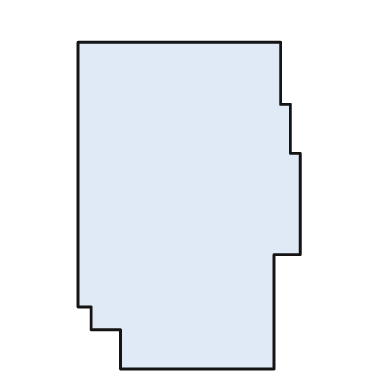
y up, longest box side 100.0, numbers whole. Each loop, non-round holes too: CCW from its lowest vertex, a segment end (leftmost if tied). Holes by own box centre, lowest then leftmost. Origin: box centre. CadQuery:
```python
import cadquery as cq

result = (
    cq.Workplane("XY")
    .moveTo(-21.0, -50.0)
    .lineTo(26.0, -50.0)
    .lineTo(26.0, -15.0)
    .lineTo(34.0, -15.0)
    .lineTo(34.0, 16.0)
    .lineTo(31.0, 16.0)
    .lineTo(31.0, 31.0)
    .lineTo(28.0, 31.0)
    .lineTo(28.0, 50.0)
    .lineTo(-34.0, 50.0)
    .lineTo(-34.0, -31.0)
    .lineTo(-30.0, -31.0)
    .lineTo(-30.0, -38.0)
    .lineTo(-21.0, -38.0)
    .close()
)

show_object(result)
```